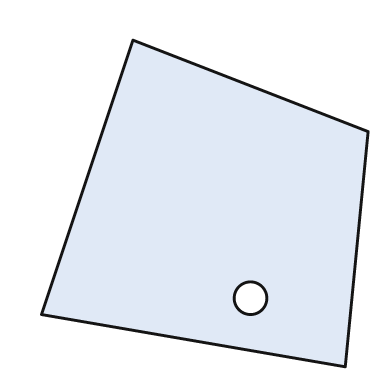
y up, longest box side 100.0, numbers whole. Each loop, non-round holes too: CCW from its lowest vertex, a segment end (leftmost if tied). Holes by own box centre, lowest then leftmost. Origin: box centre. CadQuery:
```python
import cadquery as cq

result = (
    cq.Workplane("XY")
    .moveTo(43.0, -50.0)
    .lineTo(50.0, 22.0)
    .lineTo(-22.0, 50.0)
    .lineTo(-50.0, -34.0)
    .close()
    .moveTo(14.0, -29.0)
    .circle(5.0)
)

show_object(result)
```